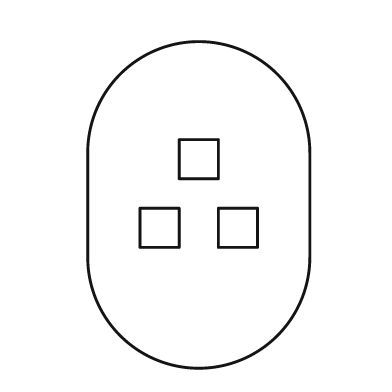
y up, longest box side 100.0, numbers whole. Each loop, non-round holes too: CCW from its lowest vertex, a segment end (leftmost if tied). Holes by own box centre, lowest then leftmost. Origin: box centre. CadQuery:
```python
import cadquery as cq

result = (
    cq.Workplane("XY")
    .moveTo(-34.0, -16.0)
    .threePointArc((0.0, -50.0), (34.0, -16.0))
    .lineTo(34.0, 16.0)
    .threePointArc((0.0, 50.0), (-34.0, 16.0))
    .close()
    .moveTo(-18.0, -13.0)
    .lineTo(-6.0, -13.0)
    .lineTo(-6.0, -1.0)
    .lineTo(-18.0, -1.0)
    .close()
    .moveTo(6.0, -13.0)
    .lineTo(18.0, -13.0)
    .lineTo(18.0, -1.0)
    .lineTo(6.0, -1.0)
    .close()
    .moveTo(-6.0, 8.0)
    .lineTo(6.0, 8.0)
    .lineTo(6.0, 20.0)
    .lineTo(-6.0, 20.0)
    .close()
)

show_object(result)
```